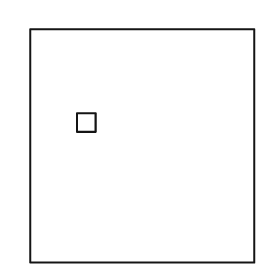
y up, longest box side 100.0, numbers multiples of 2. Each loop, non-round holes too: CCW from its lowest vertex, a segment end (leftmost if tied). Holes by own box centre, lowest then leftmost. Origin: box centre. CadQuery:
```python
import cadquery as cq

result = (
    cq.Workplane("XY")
    .moveTo(-48.0, -50.0)
    .lineTo(48.0, -50.0)
    .lineTo(48.0, 50.0)
    .lineTo(-48.0, 50.0)
    .close()
    .moveTo(-28.0, 6.0)
    .lineTo(-20.0, 6.0)
    .lineTo(-20.0, 14.0)
    .lineTo(-28.0, 14.0)
    .close()
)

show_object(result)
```